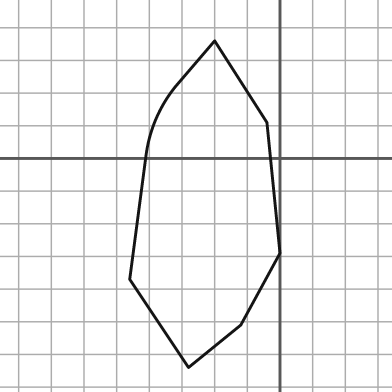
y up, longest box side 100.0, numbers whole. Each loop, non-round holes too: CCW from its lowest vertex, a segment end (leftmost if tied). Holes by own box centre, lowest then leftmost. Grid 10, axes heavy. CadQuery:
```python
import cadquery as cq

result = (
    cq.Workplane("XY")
    .moveTo(-28.0, -64.0)
    .lineTo(-12.0, -51.0)
    .lineTo(0.0, -29.0)
    .lineTo(-4.0, 11.0)
    .lineTo(-20.0, 36.0)
    .lineTo(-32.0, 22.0)
    .threePointArc((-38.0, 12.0), (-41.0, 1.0))
    .lineTo(-46.0, -37.0)
    .close()
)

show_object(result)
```